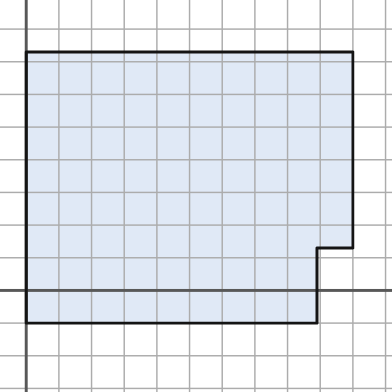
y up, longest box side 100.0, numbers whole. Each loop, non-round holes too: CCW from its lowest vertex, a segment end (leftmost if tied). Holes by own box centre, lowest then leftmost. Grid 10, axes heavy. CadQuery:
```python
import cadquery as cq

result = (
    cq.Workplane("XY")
    .moveTo(0.0, -10.0)
    .lineTo(89.0, -10.0)
    .lineTo(89.0, 13.0)
    .lineTo(100.0, 13.0)
    .lineTo(100.0, 73.0)
    .lineTo(0.0, 73.0)
    .close()
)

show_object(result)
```